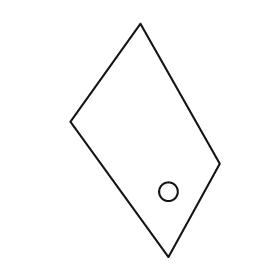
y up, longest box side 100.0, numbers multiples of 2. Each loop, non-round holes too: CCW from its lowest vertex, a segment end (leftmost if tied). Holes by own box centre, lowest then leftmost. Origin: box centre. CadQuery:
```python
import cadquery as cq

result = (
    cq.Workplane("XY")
    .moveTo(10.0, -50.0)
    .lineTo(32.0, -10.0)
    .lineTo(-2.0, 50.0)
    .lineTo(-32.0, 8.0)
    .close()
    .moveTo(10.0, -22.0)
    .circle(4.0)
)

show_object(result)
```